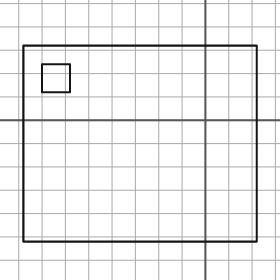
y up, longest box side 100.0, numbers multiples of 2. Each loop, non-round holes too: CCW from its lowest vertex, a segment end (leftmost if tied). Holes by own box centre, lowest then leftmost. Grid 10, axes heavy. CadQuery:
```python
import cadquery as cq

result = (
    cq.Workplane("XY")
    .moveTo(-78.0, -52.0)
    .lineTo(22.0, -52.0)
    .lineTo(22.0, 32.0)
    .lineTo(-78.0, 32.0)
    .close()
    .moveTo(-70.0, 12.0)
    .lineTo(-58.0, 12.0)
    .lineTo(-58.0, 24.0)
    .lineTo(-70.0, 24.0)
    .close()
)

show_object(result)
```